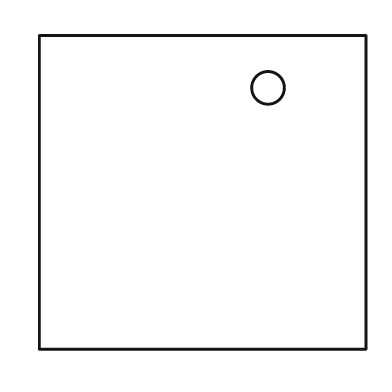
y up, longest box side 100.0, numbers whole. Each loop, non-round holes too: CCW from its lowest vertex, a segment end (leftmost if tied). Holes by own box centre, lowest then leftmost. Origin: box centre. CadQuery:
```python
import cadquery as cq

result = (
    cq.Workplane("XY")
    .moveTo(-50.0, -48.0)
    .lineTo(50.0, -48.0)
    .lineTo(50.0, 48.0)
    .lineTo(-50.0, 48.0)
    .close()
    .moveTo(20.0, 32.0)
    .circle(5.0)
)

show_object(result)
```